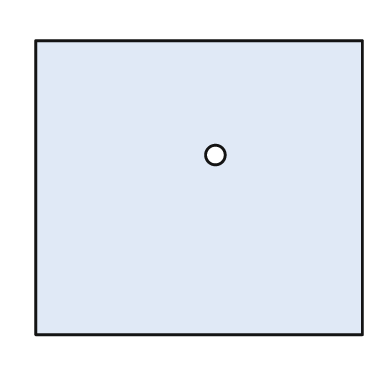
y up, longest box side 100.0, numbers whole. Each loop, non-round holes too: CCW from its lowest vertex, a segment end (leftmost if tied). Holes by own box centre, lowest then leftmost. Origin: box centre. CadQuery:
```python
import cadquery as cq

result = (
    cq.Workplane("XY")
    .moveTo(-50.0, -45.0)
    .lineTo(50.0, -45.0)
    .lineTo(50.0, 45.0)
    .lineTo(-50.0, 45.0)
    .close()
    .moveTo(5.0, 10.0)
    .circle(3.0)
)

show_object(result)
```